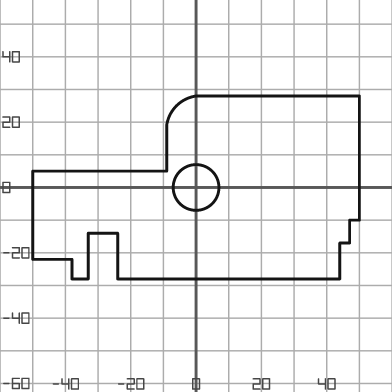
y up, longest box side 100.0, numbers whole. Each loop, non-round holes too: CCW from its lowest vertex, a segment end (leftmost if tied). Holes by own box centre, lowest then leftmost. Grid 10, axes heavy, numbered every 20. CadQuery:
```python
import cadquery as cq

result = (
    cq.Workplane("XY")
    .moveTo(-38.0, -28.0)
    .lineTo(-33.0, -28.0)
    .lineTo(-33.0, -14.0)
    .lineTo(-24.0, -14.0)
    .lineTo(-24.0, -28.0)
    .lineTo(44.0, -28.0)
    .lineTo(44.0, -17.0)
    .lineTo(47.0, -17.0)
    .lineTo(47.0, -10.0)
    .lineTo(50.0, -10.0)
    .lineTo(50.0, 28.0)
    .lineTo(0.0, 28.0)
    .threePointArc((-6.0, 25.0), (-9.0, 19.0))
    .lineTo(-9.0, 5.0)
    .lineTo(-50.0, 5.0)
    .lineTo(-50.0, -22.0)
    .lineTo(-38.0, -22.0)
    .close()
    .moveTo(0.0, 0.0)
    .circle(7.0)
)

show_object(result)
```